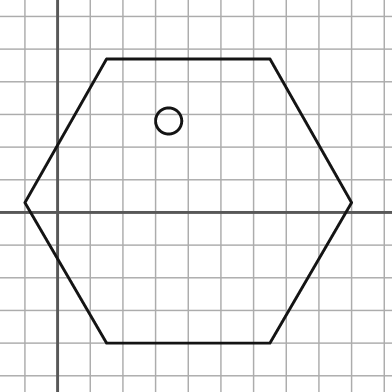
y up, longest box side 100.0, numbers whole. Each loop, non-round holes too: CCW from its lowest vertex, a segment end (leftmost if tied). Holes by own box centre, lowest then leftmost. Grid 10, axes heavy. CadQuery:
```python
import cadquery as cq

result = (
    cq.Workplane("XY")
    .moveTo(15.0, -40.0)
    .lineTo(65.0, -40.0)
    .lineTo(90.0, 3.0)
    .lineTo(65.0, 47.0)
    .lineTo(15.0, 47.0)
    .lineTo(-10.0, 3.0)
    .close()
    .moveTo(34.0, 28.0)
    .circle(4.0)
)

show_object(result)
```